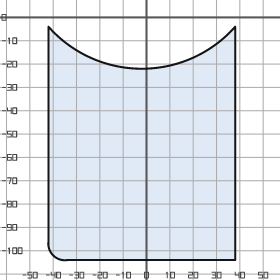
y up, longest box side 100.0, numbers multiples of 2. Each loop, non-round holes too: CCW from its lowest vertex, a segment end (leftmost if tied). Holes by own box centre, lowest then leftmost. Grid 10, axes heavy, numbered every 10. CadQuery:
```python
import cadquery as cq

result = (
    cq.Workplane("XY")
    .moveTo(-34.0, -104.0)
    .lineTo(38.0, -104.0)
    .lineTo(38.0, -4.0)
    .threePointArc((-2.0, -22.0), (-42.0, -4.0))
    .lineTo(-42.0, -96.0)
    .threePointArc((-40.0, -102.0), (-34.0, -104.0))
    .close()
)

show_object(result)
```